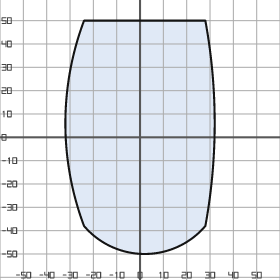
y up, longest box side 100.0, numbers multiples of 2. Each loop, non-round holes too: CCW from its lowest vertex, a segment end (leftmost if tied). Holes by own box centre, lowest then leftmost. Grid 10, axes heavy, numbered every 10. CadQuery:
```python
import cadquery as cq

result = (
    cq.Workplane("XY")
    .moveTo(-24.0, -38.0)
    .threePointArc((2.0, -50.0), (28.0, -38.0))
    .threePointArc((32.0, 6.0), (28.0, 50.0))
    .lineTo(-24.0, 50.0)
    .threePointArc((-32.0, 6.0), (-24.0, -38.0))
    .close()
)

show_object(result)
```